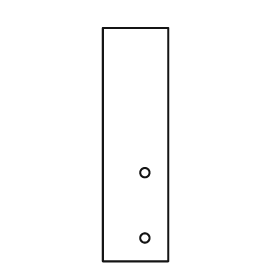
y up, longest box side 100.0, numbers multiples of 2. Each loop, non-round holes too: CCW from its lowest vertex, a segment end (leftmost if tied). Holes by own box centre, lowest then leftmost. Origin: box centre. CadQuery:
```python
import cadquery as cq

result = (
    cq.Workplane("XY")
    .moveTo(-14.0, -50.0)
    .lineTo(14.0, -50.0)
    .lineTo(14.0, 50.0)
    .lineTo(-14.0, 50.0)
    .close()
    .moveTo(4.0, -40.0)
    .circle(2.0)
    .moveTo(4.0, -12.0)
    .circle(2.0)
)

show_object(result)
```